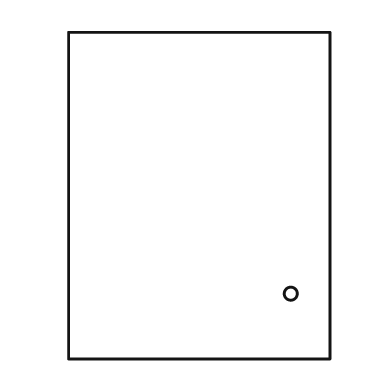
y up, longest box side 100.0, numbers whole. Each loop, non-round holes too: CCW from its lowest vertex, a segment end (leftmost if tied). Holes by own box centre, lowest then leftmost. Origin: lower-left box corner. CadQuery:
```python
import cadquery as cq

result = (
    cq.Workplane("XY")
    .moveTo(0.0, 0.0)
    .lineTo(80.0, 0.0)
    .lineTo(80.0, 100.0)
    .lineTo(0.0, 100.0)
    .close()
    .moveTo(68.0, 20.0)
    .circle(2.0)
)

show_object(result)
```